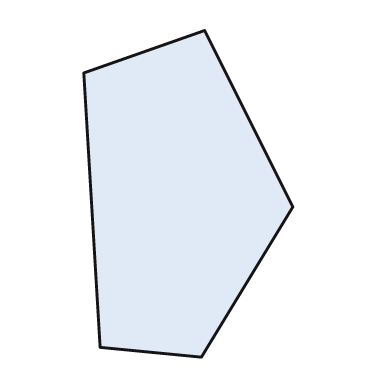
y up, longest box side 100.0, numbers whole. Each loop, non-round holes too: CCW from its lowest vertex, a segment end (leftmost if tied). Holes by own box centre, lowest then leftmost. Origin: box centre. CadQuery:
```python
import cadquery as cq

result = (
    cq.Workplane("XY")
    .moveTo(4.0, -50.0)
    .lineTo(32.0, -4.0)
    .lineTo(5.0, 50.0)
    .lineTo(-32.0, 37.0)
    .lineTo(-27.0, -47.0)
    .close()
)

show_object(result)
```